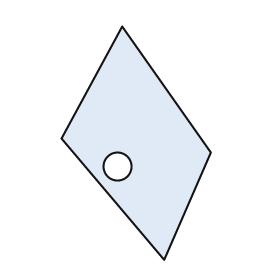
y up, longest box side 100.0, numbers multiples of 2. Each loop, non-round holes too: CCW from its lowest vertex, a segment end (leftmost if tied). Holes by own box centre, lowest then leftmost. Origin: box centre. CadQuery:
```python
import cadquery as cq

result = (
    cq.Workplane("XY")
    .moveTo(12.0, -50.0)
    .lineTo(32.0, -4.0)
    .lineTo(-6.0, 50.0)
    .lineTo(-32.0, 2.0)
    .close()
    .moveTo(-8.0, -10.0)
    .circle(6.0)
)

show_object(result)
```